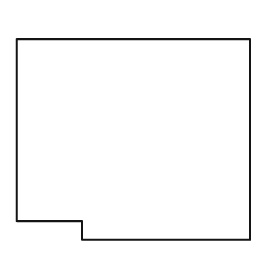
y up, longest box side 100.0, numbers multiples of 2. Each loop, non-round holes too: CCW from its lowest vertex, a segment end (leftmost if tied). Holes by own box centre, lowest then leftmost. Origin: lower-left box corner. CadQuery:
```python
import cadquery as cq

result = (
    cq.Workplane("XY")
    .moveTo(28.0, 0.0)
    .lineTo(100.0, 0.0)
    .lineTo(100.0, 86.0)
    .lineTo(0.0, 86.0)
    .lineTo(0.0, 8.0)
    .lineTo(28.0, 8.0)
    .close()
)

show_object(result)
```